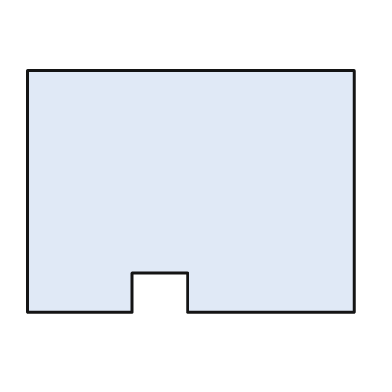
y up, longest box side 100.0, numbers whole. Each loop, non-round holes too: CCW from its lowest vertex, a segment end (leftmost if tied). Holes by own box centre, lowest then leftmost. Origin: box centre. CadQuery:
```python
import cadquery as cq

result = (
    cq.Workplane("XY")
    .moveTo(-50.0, -37.0)
    .lineTo(-18.0, -37.0)
    .lineTo(-18.0, -25.0)
    .lineTo(-1.0, -25.0)
    .lineTo(-1.0, -37.0)
    .lineTo(50.0, -37.0)
    .lineTo(50.0, 37.0)
    .lineTo(-50.0, 37.0)
    .close()
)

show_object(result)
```